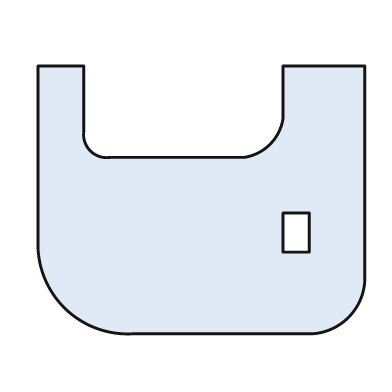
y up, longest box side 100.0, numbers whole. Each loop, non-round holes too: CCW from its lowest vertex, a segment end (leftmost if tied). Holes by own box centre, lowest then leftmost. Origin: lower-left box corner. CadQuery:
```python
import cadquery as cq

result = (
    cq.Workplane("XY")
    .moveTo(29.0, 0.0)
    .lineTo(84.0, 0.0)
    .threePointArc((95.0, 5.0), (100.0, 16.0))
    .lineTo(100.0, 82.0)
    .lineTo(75.0, 82.0)
    .lineTo(75.0, 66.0)
    .threePointArc((71.0, 58.0), (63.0, 54.0))
    .lineTo(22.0, 54.0)
    .threePointArc((16.0, 56.0), (14.0, 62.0))
    .lineTo(14.0, 82.0)
    .lineTo(0.0, 82.0)
    .lineTo(0.0, 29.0)
    .threePointArc((8.0, 8.0), (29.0, 0.0))
    .close()
    .moveTo(75.0, 25.0)
    .lineTo(83.0, 25.0)
    .lineTo(83.0, 37.0)
    .lineTo(75.0, 37.0)
    .close()
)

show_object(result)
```